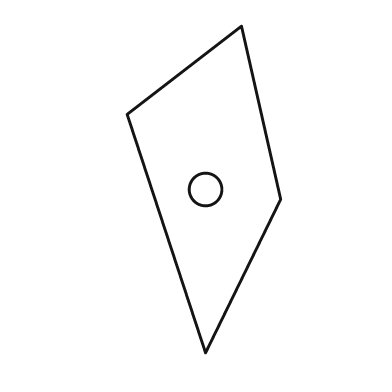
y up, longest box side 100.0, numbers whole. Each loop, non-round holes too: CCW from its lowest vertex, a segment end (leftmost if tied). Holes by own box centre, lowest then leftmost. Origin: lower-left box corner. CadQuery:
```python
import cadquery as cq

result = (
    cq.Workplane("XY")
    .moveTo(24.0, 0.0)
    .lineTo(47.0, 47.0)
    .lineTo(35.0, 100.0)
    .lineTo(0.0, 73.0)
    .close()
    .moveTo(24.0, 50.0)
    .circle(5.0)
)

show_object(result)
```